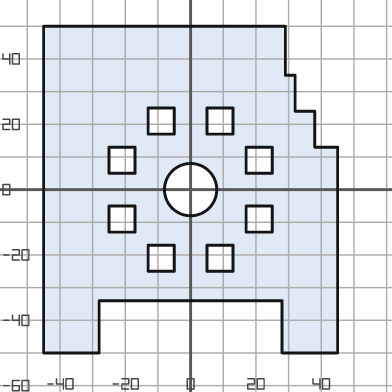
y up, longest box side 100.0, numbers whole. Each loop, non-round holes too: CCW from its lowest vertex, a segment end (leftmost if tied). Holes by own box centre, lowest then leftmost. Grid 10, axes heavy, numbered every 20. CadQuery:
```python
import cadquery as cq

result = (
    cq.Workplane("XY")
    .moveTo(-45.0, -50.0)
    .lineTo(-28.0, -50.0)
    .lineTo(-28.0, -34.0)
    .lineTo(28.0, -34.0)
    .lineTo(28.0, -50.0)
    .lineTo(45.0, -50.0)
    .lineTo(45.0, 13.0)
    .lineTo(38.0, 13.0)
    .lineTo(38.0, 24.0)
    .lineTo(32.0, 24.0)
    .lineTo(32.0, 35.0)
    .lineTo(29.0, 35.0)
    .lineTo(29.0, 50.0)
    .lineTo(-45.0, 50.0)
    .close()
    .moveTo(-13.0, -25.0)
    .lineTo(-5.0, -25.0)
    .lineTo(-5.0, -17.0)
    .lineTo(-13.0, -17.0)
    .close()
    .moveTo(5.0, -25.0)
    .lineTo(13.0, -25.0)
    .lineTo(13.0, -17.0)
    .lineTo(5.0, -17.0)
    .close()
    .moveTo(-25.0, -13.0)
    .lineTo(-17.0, -13.0)
    .lineTo(-17.0, -5.0)
    .lineTo(-25.0, -5.0)
    .close()
    .moveTo(17.0, -13.0)
    .lineTo(25.0, -13.0)
    .lineTo(25.0, -5.0)
    .lineTo(17.0, -5.0)
    .close()
    .moveTo(0.0, 0.0)
    .circle(8.0)
    .moveTo(-25.0, 5.0)
    .lineTo(-17.0, 5.0)
    .lineTo(-17.0, 13.0)
    .lineTo(-25.0, 13.0)
    .close()
    .moveTo(17.0, 5.0)
    .lineTo(25.0, 5.0)
    .lineTo(25.0, 13.0)
    .lineTo(17.0, 13.0)
    .close()
    .moveTo(-13.0, 17.0)
    .lineTo(-5.0, 17.0)
    .lineTo(-5.0, 25.0)
    .lineTo(-13.0, 25.0)
    .close()
    .moveTo(5.0, 17.0)
    .lineTo(13.0, 17.0)
    .lineTo(13.0, 25.0)
    .lineTo(5.0, 25.0)
    .close()
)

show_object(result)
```